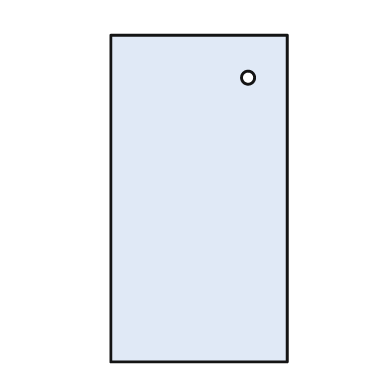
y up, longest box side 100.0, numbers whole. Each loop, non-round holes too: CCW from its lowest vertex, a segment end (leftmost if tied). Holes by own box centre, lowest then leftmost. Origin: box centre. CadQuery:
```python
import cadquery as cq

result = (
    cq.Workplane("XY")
    .moveTo(-27.0, -50.0)
    .lineTo(27.0, -50.0)
    .lineTo(27.0, 50.0)
    .lineTo(-27.0, 50.0)
    .close()
    .moveTo(15.0, 37.0)
    .circle(2.0)
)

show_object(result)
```